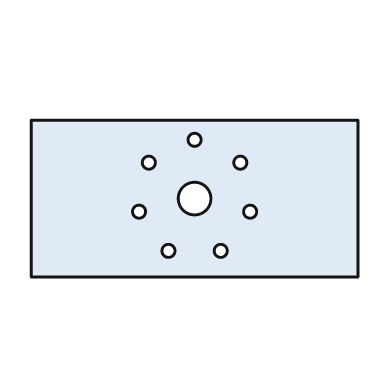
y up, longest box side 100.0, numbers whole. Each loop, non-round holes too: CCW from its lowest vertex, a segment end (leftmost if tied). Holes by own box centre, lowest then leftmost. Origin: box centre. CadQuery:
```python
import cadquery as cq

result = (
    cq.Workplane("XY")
    .moveTo(-50.0, -24.0)
    .lineTo(50.0, -24.0)
    .lineTo(50.0, 24.0)
    .lineTo(-50.0, 24.0)
    .close()
    .moveTo(-8.0, -16.0)
    .circle(2.0)
    .moveTo(8.0, -16.0)
    .circle(2.0)
    .moveTo(-17.0, -4.0)
    .circle(2.0)
    .moveTo(17.0, -4.0)
    .circle(2.0)
    .moveTo(0.0, 0.0)
    .circle(5.0)
    .moveTo(-14.0, 11.0)
    .circle(2.0)
    .moveTo(14.0, 11.0)
    .circle(2.0)
    .moveTo(0.0, 18.0)
    .circle(2.0)
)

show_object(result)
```